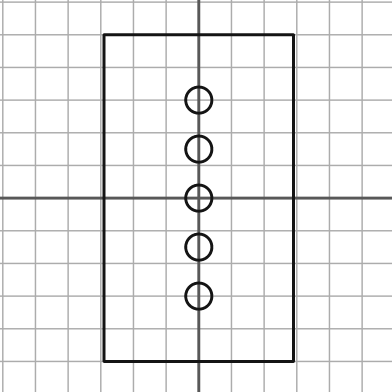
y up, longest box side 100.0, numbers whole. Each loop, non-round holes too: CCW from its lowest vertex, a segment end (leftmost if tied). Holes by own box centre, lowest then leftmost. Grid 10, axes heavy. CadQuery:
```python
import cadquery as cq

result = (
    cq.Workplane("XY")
    .moveTo(-29.0, -50.0)
    .lineTo(29.0, -50.0)
    .lineTo(29.0, 50.0)
    .lineTo(-29.0, 50.0)
    .close()
    .moveTo(0.0, -30.0)
    .circle(4.0)
    .moveTo(0.0, -15.0)
    .circle(4.0)
    .moveTo(0.0, 0.0)
    .circle(4.0)
    .moveTo(0.0, 15.0)
    .circle(4.0)
    .moveTo(0.0, 30.0)
    .circle(4.0)
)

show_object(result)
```